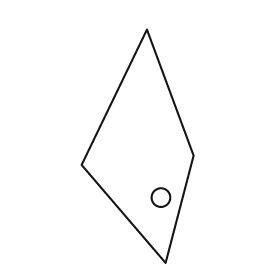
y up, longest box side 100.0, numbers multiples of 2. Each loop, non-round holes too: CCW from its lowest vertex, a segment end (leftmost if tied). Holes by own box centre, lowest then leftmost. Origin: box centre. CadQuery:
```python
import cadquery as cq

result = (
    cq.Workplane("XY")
    .moveTo(12.0, -50.0)
    .lineTo(24.0, -4.0)
    .lineTo(4.0, 50.0)
    .lineTo(-24.0, -8.0)
    .close()
    .moveTo(10.0, -22.0)
    .circle(4.0)
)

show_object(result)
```